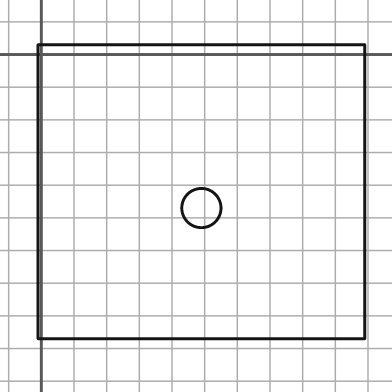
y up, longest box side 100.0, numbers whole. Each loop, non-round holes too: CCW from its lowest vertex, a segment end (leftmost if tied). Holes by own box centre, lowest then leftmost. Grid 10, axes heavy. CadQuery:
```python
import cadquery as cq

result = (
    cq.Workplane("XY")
    .moveTo(-1.0, -87.0)
    .lineTo(99.0, -87.0)
    .lineTo(99.0, 3.0)
    .lineTo(-1.0, 3.0)
    .close()
    .moveTo(49.0, -47.0)
    .circle(6.0)
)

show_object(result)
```